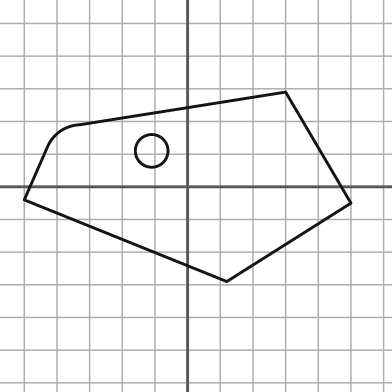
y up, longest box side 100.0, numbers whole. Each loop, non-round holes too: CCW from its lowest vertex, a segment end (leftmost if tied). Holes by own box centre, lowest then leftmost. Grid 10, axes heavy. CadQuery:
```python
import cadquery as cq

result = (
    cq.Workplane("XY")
    .moveTo(12.0, -29.0)
    .lineTo(50.0, -5.0)
    .lineTo(30.0, 29.0)
    .lineTo(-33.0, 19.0)
    .threePointArc((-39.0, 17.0), (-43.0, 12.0))
    .lineTo(-50.0, -4.0)
    .close()
    .moveTo(-11.0, 11.0)
    .circle(5.0)
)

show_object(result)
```